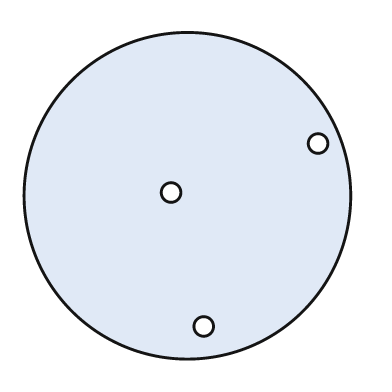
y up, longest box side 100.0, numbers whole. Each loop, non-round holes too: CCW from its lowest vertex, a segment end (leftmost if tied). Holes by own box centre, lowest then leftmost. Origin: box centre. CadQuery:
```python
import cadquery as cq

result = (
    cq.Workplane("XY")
    .moveTo(0.0, 0.0)
    .circle(50.0)
    .moveTo(5.0, -40.0)
    .circle(3.0)
    .moveTo(-5.0, 1.0)
    .circle(3.0)
    .moveTo(40.0, 16.0)
    .circle(3.0)
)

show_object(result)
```